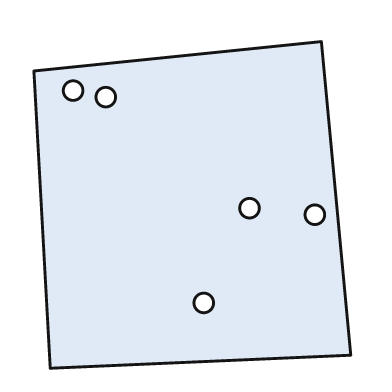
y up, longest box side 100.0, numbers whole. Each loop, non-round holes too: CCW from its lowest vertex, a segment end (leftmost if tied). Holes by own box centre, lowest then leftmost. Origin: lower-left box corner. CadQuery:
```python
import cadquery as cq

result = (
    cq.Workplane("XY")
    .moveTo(5.0, 0.0)
    .lineTo(97.0, 4.0)
    .lineTo(88.0, 100.0)
    .lineTo(0.0, 91.0)
    .close()
    .moveTo(52.0, 20.0)
    .circle(3.0)
    .moveTo(86.0, 47.0)
    .circle(3.0)
    .moveTo(66.0, 49.0)
    .circle(3.0)
    .moveTo(22.0, 83.0)
    .circle(3.0)
    .moveTo(12.0, 85.0)
    .circle(3.0)
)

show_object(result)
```